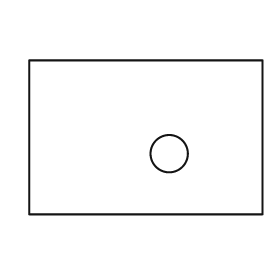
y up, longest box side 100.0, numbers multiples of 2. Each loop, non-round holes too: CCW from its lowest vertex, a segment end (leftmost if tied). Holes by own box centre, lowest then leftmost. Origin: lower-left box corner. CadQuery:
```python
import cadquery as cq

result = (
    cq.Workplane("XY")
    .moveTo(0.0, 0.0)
    .lineTo(100.0, 0.0)
    .lineTo(100.0, 66.0)
    .lineTo(0.0, 66.0)
    .close()
    .moveTo(60.0, 26.0)
    .circle(8.0)
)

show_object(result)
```